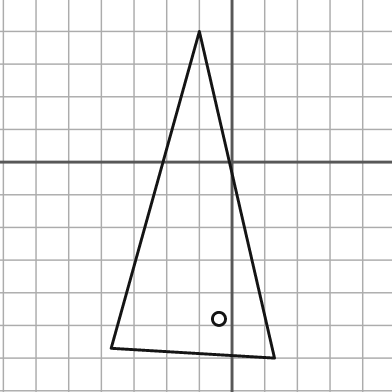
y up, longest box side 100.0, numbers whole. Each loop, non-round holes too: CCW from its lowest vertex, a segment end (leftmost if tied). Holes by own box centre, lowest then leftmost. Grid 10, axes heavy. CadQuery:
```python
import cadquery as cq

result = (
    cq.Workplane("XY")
    .moveTo(13.0, -60.0)
    .lineTo(-10.0, 40.0)
    .lineTo(-37.0, -57.0)
    .close()
    .moveTo(-4.0, -48.0)
    .circle(2.0)
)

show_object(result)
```